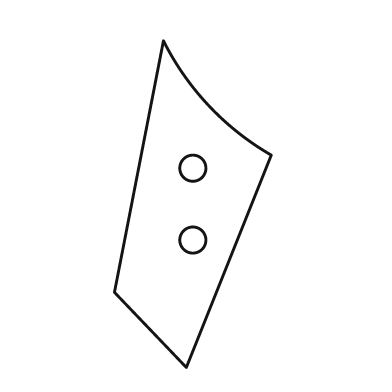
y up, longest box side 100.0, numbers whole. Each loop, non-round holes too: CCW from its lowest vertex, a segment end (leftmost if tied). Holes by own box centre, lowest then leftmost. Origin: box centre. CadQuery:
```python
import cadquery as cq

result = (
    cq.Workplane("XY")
    .moveTo(-2.0, -50.0)
    .lineTo(24.0, 15.0)
    .threePointArc((5.0, 30.0), (-9.0, 50.0))
    .lineTo(-24.0, -27.0)
    .close()
    .moveTo(0.0, -11.0)
    .circle(4.0)
    .moveTo(0.0, 11.0)
    .circle(4.0)
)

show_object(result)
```